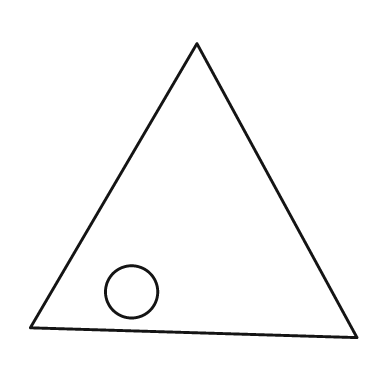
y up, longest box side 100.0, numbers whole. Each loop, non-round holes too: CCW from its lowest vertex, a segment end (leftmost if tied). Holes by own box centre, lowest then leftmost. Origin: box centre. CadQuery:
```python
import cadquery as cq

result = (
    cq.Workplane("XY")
    .moveTo(50.0, -45.0)
    .lineTo(1.0, 45.0)
    .lineTo(-50.0, -42.0)
    .close()
    .moveTo(-19.0, -31.0)
    .circle(8.0)
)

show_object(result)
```